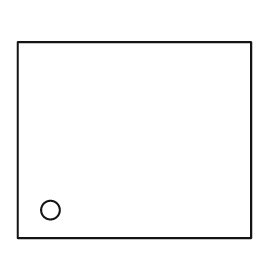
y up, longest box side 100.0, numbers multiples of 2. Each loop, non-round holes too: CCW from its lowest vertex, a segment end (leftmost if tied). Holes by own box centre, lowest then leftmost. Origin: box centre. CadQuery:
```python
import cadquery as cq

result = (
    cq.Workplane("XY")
    .moveTo(-50.0, -42.0)
    .lineTo(50.0, -42.0)
    .lineTo(50.0, 42.0)
    .lineTo(-50.0, 42.0)
    .close()
    .moveTo(-36.0, -30.0)
    .circle(4.0)
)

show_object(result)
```